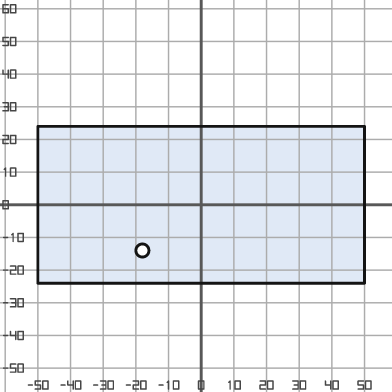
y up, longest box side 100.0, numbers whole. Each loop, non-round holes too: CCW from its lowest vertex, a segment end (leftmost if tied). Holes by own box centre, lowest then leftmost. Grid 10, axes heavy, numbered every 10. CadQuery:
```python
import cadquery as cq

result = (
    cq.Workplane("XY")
    .moveTo(-50.0, -24.0)
    .lineTo(50.0, -24.0)
    .lineTo(50.0, 24.0)
    .lineTo(-50.0, 24.0)
    .close()
    .moveTo(-18.0, -14.0)
    .circle(2.0)
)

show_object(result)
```